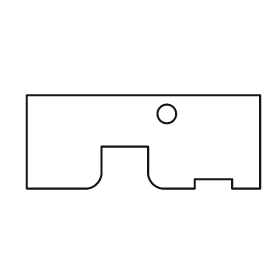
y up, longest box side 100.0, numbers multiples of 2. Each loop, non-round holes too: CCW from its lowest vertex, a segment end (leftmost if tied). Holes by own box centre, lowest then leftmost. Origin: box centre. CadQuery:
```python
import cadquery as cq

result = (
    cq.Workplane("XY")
    .moveTo(-50.0, -20.0)
    .lineTo(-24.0, -20.0)
    .threePointArc((-20.0, -18.0), (-18.0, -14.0))
    .lineTo(-18.0, -2.0)
    .lineTo(2.0, -2.0)
    .lineTo(2.0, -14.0)
    .threePointArc((4.0, -18.0), (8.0, -20.0))
    .lineTo(22.0, -20.0)
    .lineTo(22.0, -16.0)
    .lineTo(38.0, -16.0)
    .lineTo(38.0, -20.0)
    .lineTo(50.0, -20.0)
    .lineTo(50.0, 20.0)
    .lineTo(-50.0, 20.0)
    .close()
    .moveTo(10.0, 12.0)
    .circle(4.0)
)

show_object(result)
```